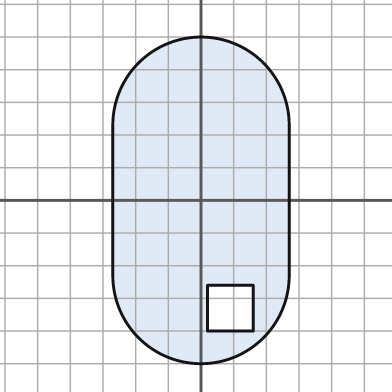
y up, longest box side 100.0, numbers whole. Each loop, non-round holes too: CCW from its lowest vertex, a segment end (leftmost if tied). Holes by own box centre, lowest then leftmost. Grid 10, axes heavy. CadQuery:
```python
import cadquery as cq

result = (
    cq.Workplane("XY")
    .moveTo(-27.0, -23.0)
    .threePointArc((0.0, -50.0), (27.0, -23.0))
    .lineTo(27.0, 23.0)
    .threePointArc((0.0, 50.0), (-27.0, 23.0))
    .close()
    .moveTo(2.0, -40.0)
    .lineTo(16.0, -40.0)
    .lineTo(16.0, -26.0)
    .lineTo(2.0, -26.0)
    .close()
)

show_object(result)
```